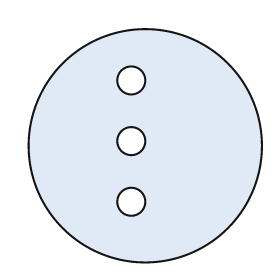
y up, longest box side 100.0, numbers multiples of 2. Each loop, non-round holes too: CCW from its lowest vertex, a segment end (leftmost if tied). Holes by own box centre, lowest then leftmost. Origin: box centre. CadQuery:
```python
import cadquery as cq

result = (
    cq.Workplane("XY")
    .moveTo(0.0, 0.0)
    .circle(50.0)
    .moveTo(-6.0, -24.0)
    .circle(6.0)
    .moveTo(-6.0, 2.0)
    .circle(6.0)
    .moveTo(-6.0, 28.0)
    .circle(6.0)
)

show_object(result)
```